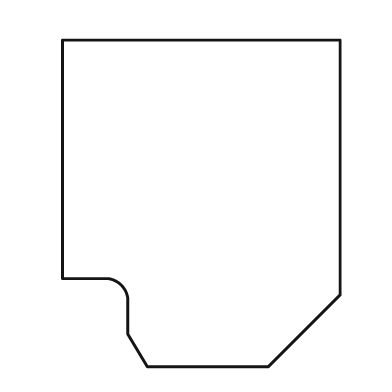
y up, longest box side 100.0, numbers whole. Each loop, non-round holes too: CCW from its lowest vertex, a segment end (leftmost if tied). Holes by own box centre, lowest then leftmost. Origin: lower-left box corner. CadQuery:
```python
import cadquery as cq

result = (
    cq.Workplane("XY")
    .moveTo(26.0, 0.0)
    .lineTo(63.0, 0.0)
    .lineTo(85.0, 22.0)
    .lineTo(85.0, 100.0)
    .lineTo(0.0, 100.0)
    .lineTo(0.0, 27.0)
    .lineTo(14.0, 27.0)
    .threePointArc((18.0, 25.0), (20.0, 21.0))
    .lineTo(20.0, 10.0)
    .close()
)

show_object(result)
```